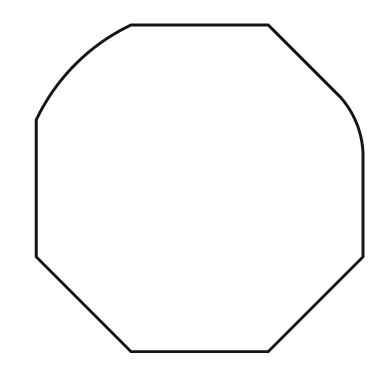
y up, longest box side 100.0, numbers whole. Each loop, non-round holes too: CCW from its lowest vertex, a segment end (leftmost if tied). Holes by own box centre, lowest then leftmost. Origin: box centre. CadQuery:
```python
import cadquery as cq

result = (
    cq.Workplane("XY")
    .moveTo(-21.0, -50.0)
    .lineTo(21.0, -50.0)
    .lineTo(50.0, -21.0)
    .lineTo(50.0, 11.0)
    .threePointArc((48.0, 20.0), (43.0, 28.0))
    .lineTo(21.0, 50.0)
    .lineTo(-21.0, 50.0)
    .threePointArc((-38.0, 38.0), (-50.0, 21.0))
    .lineTo(-50.0, -21.0)
    .close()
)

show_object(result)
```